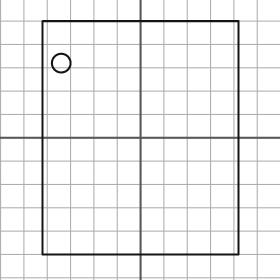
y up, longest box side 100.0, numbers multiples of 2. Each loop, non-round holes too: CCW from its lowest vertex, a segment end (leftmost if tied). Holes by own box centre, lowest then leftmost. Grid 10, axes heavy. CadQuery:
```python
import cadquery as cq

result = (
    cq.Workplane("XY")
    .moveTo(-42.0, -50.0)
    .lineTo(42.0, -50.0)
    .lineTo(42.0, 50.0)
    .lineTo(-42.0, 50.0)
    .close()
    .moveTo(-34.0, 32.0)
    .circle(4.0)
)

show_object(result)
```